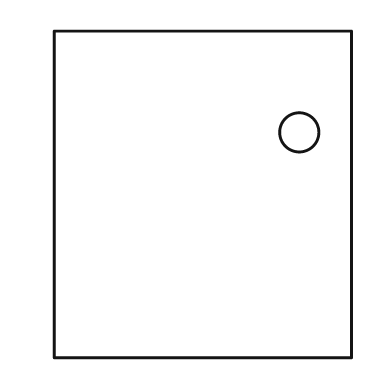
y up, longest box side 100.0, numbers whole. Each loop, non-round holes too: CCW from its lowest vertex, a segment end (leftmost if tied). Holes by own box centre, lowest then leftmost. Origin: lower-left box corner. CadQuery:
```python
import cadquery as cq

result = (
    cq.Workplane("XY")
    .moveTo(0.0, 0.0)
    .lineTo(91.0, 0.0)
    .lineTo(91.0, 100.0)
    .lineTo(0.0, 100.0)
    .close()
    .moveTo(75.0, 69.0)
    .circle(6.0)
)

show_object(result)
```